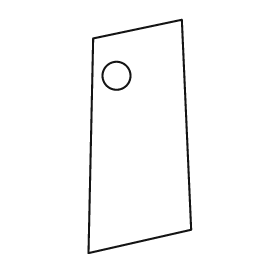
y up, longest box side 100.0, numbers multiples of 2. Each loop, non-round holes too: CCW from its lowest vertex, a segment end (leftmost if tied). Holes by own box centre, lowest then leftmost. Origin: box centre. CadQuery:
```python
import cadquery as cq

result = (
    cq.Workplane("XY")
    .moveTo(-22.0, -50.0)
    .lineTo(22.0, -40.0)
    .lineTo(18.0, 50.0)
    .lineTo(-20.0, 42.0)
    .close()
    .moveTo(-10.0, 26.0)
    .circle(6.0)
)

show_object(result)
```